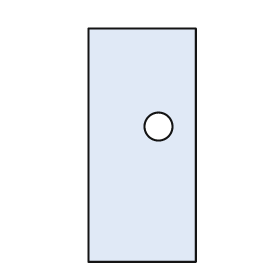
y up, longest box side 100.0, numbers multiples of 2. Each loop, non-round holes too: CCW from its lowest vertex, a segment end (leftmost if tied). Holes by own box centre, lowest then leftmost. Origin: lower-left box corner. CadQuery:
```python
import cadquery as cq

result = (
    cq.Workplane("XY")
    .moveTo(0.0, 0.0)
    .lineTo(46.0, 0.0)
    .lineTo(46.0, 100.0)
    .lineTo(0.0, 100.0)
    .close()
    .moveTo(30.0, 58.0)
    .circle(6.0)
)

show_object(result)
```